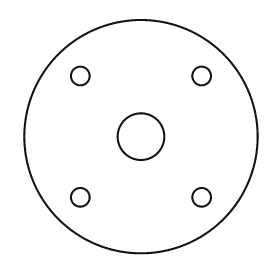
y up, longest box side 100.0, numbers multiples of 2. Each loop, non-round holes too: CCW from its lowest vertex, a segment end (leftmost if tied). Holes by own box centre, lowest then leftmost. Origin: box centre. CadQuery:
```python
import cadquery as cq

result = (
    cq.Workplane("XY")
    .moveTo(0.0, 0.0)
    .circle(50.0)
    .moveTo(-26.0, -26.0)
    .circle(4.0)
    .moveTo(26.0, -26.0)
    .circle(4.0)
    .moveTo(0.0, 0.0)
    .circle(10.0)
    .moveTo(-26.0, 26.0)
    .circle(4.0)
    .moveTo(26.0, 26.0)
    .circle(4.0)
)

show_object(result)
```